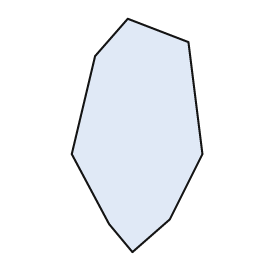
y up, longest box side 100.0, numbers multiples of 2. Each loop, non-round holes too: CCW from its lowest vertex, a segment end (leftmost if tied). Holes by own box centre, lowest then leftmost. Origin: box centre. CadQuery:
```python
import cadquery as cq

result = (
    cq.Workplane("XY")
    .moveTo(-2.0, -50.0)
    .lineTo(14.0, -36.0)
    .lineTo(28.0, -8.0)
    .lineTo(22.0, 40.0)
    .lineTo(-4.0, 50.0)
    .lineTo(-18.0, 34.0)
    .lineTo(-28.0, -8.0)
    .lineTo(-12.0, -38.0)
    .close()
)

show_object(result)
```